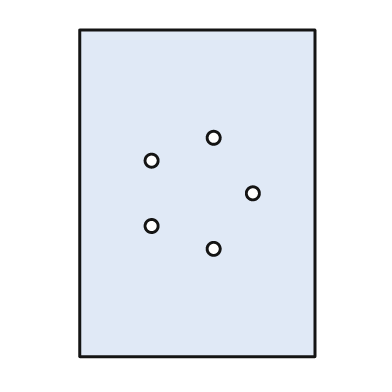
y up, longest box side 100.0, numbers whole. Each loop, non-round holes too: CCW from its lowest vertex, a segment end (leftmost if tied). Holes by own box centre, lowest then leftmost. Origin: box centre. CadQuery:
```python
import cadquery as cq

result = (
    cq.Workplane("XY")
    .moveTo(-36.0, -50.0)
    .lineTo(36.0, -50.0)
    .lineTo(36.0, 50.0)
    .lineTo(-36.0, 50.0)
    .close()
    .moveTo(5.0, -17.0)
    .circle(2.0)
    .moveTo(-14.0, -10.0)
    .circle(2.0)
    .moveTo(17.0, 0.0)
    .circle(2.0)
    .moveTo(-14.0, 10.0)
    .circle(2.0)
    .moveTo(5.0, 17.0)
    .circle(2.0)
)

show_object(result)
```